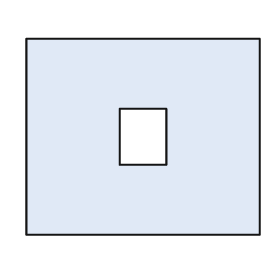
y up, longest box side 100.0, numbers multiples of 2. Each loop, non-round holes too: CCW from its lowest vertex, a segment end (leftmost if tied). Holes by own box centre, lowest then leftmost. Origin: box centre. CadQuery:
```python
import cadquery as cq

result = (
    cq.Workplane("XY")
    .moveTo(-50.0, -42.0)
    .lineTo(50.0, -42.0)
    .lineTo(50.0, 42.0)
    .lineTo(-50.0, 42.0)
    .close()
    .moveTo(-10.0, -12.0)
    .lineTo(10.0, -12.0)
    .lineTo(10.0, 12.0)
    .lineTo(-10.0, 12.0)
    .close()
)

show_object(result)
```